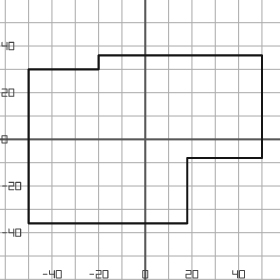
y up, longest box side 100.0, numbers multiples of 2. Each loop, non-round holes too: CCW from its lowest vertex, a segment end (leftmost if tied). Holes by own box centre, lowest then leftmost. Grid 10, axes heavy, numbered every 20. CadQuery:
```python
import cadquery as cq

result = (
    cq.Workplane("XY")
    .moveTo(-50.0, -36.0)
    .lineTo(18.0, -36.0)
    .lineTo(18.0, -8.0)
    .lineTo(50.0, -8.0)
    .lineTo(50.0, 36.0)
    .lineTo(-20.0, 36.0)
    .lineTo(-20.0, 30.0)
    .lineTo(-50.0, 30.0)
    .close()
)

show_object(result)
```